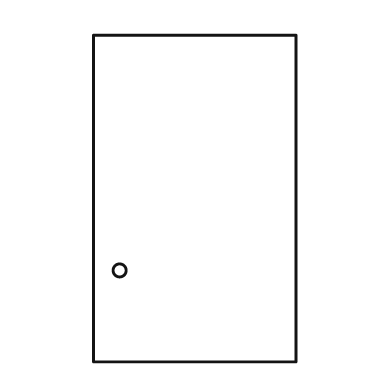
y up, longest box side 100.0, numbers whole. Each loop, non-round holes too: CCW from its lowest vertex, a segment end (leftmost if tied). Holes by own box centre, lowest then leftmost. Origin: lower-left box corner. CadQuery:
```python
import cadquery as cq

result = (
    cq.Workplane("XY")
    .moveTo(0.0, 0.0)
    .lineTo(62.0, 0.0)
    .lineTo(62.0, 100.0)
    .lineTo(0.0, 100.0)
    .close()
    .moveTo(8.0, 28.0)
    .circle(2.0)
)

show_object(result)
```